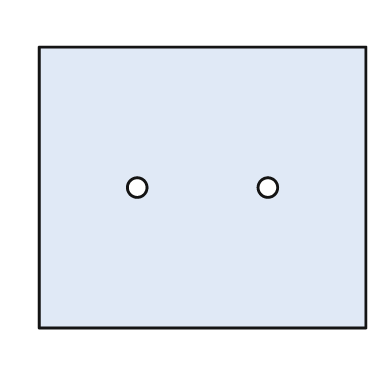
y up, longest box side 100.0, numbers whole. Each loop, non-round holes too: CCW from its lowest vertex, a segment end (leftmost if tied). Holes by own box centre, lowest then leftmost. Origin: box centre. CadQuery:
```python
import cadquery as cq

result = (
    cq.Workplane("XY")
    .moveTo(-50.0, -43.0)
    .lineTo(50.0, -43.0)
    .lineTo(50.0, 43.0)
    .lineTo(-50.0, 43.0)
    .close()
    .moveTo(-20.0, 0.0)
    .circle(3.0)
    .moveTo(20.0, 0.0)
    .circle(3.0)
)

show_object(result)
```